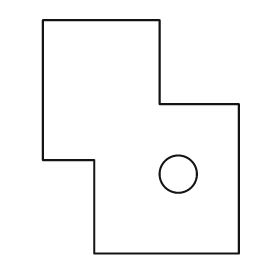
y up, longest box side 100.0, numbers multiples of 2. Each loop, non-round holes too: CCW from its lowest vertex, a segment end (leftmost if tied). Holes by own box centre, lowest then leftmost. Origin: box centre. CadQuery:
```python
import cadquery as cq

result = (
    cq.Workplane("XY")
    .moveTo(-20.0, -50.0)
    .lineTo(42.0, -50.0)
    .lineTo(42.0, 14.0)
    .lineTo(8.0, 14.0)
    .lineTo(8.0, 50.0)
    .lineTo(-42.0, 50.0)
    .lineTo(-42.0, -10.0)
    .lineTo(-20.0, -10.0)
    .close()
    .moveTo(16.0, -16.0)
    .circle(8.0)
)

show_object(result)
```